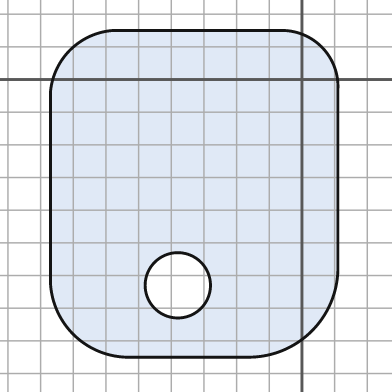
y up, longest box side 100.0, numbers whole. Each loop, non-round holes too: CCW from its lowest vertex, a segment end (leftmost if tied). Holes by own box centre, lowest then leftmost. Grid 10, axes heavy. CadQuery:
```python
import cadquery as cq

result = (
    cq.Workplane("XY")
    .moveTo(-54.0, -85.0)
    .lineTo(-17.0, -85.0)
    .threePointArc((3.0, -77.0), (11.0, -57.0))
    .lineTo(11.0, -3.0)
    .threePointArc((6.0, 10.0), (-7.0, 15.0))
    .lineTo(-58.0, 15.0)
    .threePointArc((-71.0, 9.0), (-77.0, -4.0))
    .lineTo(-77.0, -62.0)
    .threePointArc((-70.0, -78.0), (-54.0, -85.0))
    .close()
    .moveTo(-38.0, -63.0)
    .circle(10.0)
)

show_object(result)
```